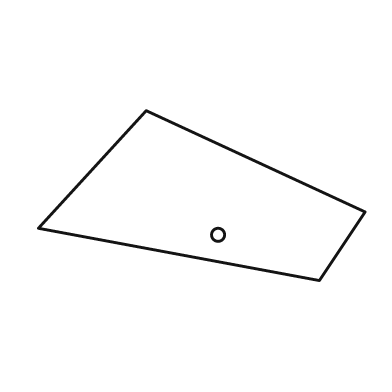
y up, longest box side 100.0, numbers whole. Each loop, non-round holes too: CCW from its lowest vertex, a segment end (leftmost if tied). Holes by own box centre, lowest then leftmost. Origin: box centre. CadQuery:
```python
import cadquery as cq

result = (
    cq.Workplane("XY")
    .moveTo(36.0, -26.0)
    .lineTo(50.0, -5.0)
    .lineTo(-17.0, 26.0)
    .lineTo(-50.0, -10.0)
    .close()
    .moveTo(5.0, -12.0)
    .circle(2.0)
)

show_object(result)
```